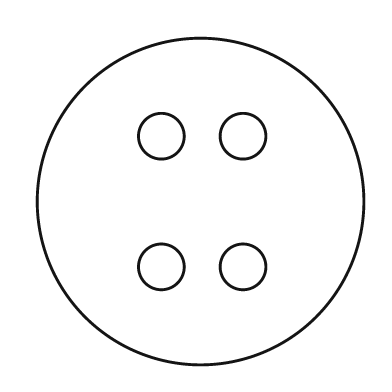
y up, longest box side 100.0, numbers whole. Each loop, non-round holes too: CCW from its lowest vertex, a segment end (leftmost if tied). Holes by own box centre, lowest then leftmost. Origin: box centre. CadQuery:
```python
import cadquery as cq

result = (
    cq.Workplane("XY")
    .moveTo(0.0, 0.0)
    .circle(50.0)
    .moveTo(-12.0, -20.0)
    .circle(7.0)
    .moveTo(13.0, -20.0)
    .circle(7.0)
    .moveTo(-12.0, 20.0)
    .circle(7.0)
    .moveTo(13.0, 20.0)
    .circle(7.0)
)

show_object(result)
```